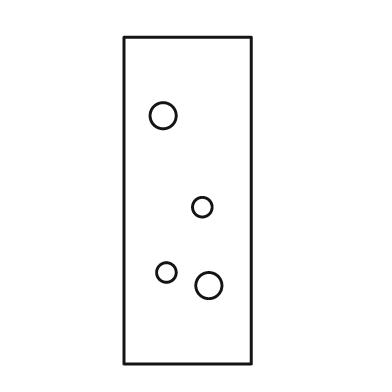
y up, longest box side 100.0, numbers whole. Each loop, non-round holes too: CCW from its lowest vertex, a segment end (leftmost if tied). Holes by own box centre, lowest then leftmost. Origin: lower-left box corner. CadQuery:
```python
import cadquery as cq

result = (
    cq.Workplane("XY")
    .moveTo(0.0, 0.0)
    .lineTo(39.0, 0.0)
    .lineTo(39.0, 100.0)
    .lineTo(0.0, 100.0)
    .close()
    .moveTo(26.0, 24.0)
    .circle(4.0)
    .moveTo(13.0, 28.0)
    .circle(3.0)
    .moveTo(24.0, 48.0)
    .circle(3.0)
    .moveTo(12.0, 76.0)
    .circle(4.0)
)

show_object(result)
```